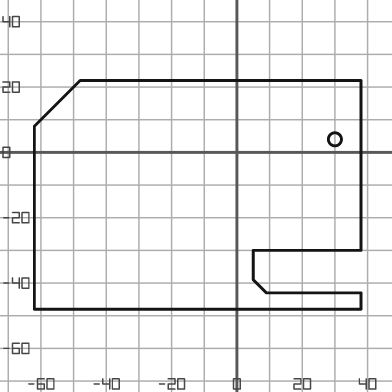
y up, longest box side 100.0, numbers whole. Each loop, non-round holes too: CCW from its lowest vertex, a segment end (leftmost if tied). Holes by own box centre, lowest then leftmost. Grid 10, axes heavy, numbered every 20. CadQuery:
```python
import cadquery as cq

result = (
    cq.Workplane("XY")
    .moveTo(-62.0, -48.0)
    .lineTo(38.0, -48.0)
    .lineTo(38.0, -43.0)
    .lineTo(9.0, -43.0)
    .lineTo(5.0, -39.0)
    .lineTo(5.0, -30.0)
    .lineTo(38.0, -30.0)
    .lineTo(38.0, 22.0)
    .lineTo(-48.0, 22.0)
    .lineTo(-62.0, 8.0)
    .close()
    .moveTo(30.0, 4.0)
    .circle(2.0)
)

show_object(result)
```